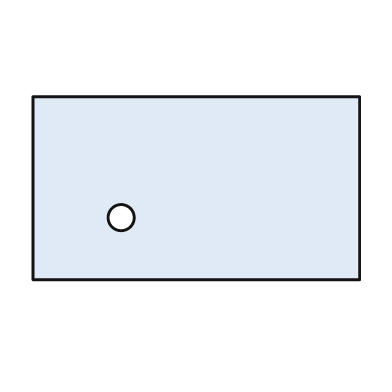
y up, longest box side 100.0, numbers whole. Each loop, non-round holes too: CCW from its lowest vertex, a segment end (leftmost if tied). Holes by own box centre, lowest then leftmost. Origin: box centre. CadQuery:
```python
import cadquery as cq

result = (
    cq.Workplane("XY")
    .moveTo(-50.0, -28.0)
    .lineTo(50.0, -28.0)
    .lineTo(50.0, 28.0)
    .lineTo(-50.0, 28.0)
    .close()
    .moveTo(-23.0, -9.0)
    .circle(4.0)
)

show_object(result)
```